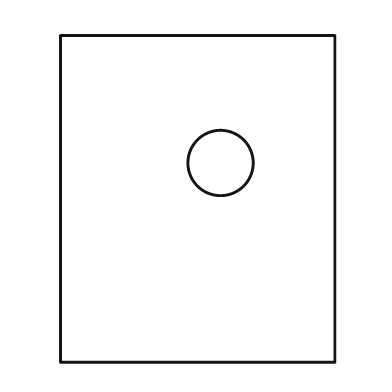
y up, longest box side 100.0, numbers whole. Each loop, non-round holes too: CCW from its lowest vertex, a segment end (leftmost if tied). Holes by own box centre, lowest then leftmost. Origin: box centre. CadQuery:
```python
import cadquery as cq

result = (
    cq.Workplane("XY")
    .moveTo(-42.0, -50.0)
    .lineTo(42.0, -50.0)
    .lineTo(42.0, 50.0)
    .lineTo(-42.0, 50.0)
    .close()
    .moveTo(7.0, 11.0)
    .circle(10.0)
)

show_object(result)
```